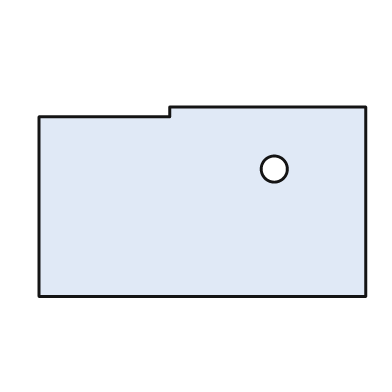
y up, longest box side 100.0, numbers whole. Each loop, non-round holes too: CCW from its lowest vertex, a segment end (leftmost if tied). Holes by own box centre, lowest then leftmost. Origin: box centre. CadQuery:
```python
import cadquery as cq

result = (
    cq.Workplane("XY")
    .moveTo(-50.0, -29.0)
    .lineTo(50.0, -29.0)
    .lineTo(50.0, 29.0)
    .lineTo(-10.0, 29.0)
    .lineTo(-10.0, 26.0)
    .lineTo(-50.0, 26.0)
    .close()
    .moveTo(22.0, 10.0)
    .circle(4.0)
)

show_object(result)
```